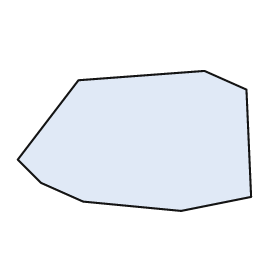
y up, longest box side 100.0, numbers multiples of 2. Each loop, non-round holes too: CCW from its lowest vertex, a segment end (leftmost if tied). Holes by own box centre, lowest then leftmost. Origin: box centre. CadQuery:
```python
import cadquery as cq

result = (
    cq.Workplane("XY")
    .moveTo(20.0, -30.0)
    .lineTo(50.0, -24.0)
    .lineTo(48.0, 22.0)
    .lineTo(30.0, 30.0)
    .lineTo(-24.0, 26.0)
    .lineTo(-50.0, -8.0)
    .lineTo(-40.0, -18.0)
    .lineTo(-22.0, -26.0)
    .close()
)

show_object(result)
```